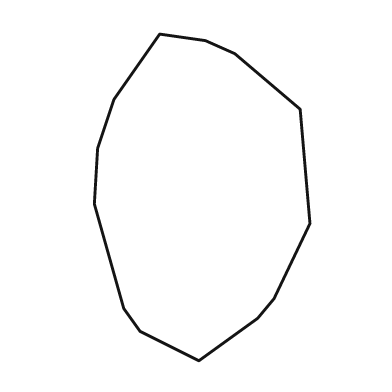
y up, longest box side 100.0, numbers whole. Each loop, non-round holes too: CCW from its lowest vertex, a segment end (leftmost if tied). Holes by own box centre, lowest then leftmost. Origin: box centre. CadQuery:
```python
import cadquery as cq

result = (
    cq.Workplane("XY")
    .moveTo(-1.0, -50.0)
    .lineTo(17.0, -37.0)
    .lineTo(22.0, -31.0)
    .lineTo(33.0, -8.0)
    .lineTo(30.0, 27.0)
    .lineTo(10.0, 44.0)
    .lineTo(1.0, 48.0)
    .lineTo(-13.0, 50.0)
    .lineTo(-27.0, 30.0)
    .lineTo(-32.0, 15.0)
    .lineTo(-33.0, -2.0)
    .lineTo(-24.0, -34.0)
    .lineTo(-19.0, -41.0)
    .close()
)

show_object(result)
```